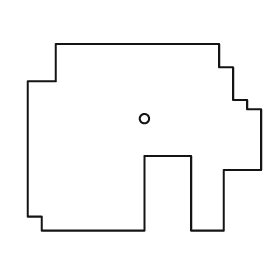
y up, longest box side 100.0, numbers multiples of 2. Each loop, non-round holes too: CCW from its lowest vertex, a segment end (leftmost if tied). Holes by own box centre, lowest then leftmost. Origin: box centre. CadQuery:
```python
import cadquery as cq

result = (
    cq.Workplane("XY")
    .moveTo(-44.0, -40.0)
    .lineTo(0.0, -40.0)
    .lineTo(0.0, -8.0)
    .lineTo(20.0, -8.0)
    .lineTo(20.0, -40.0)
    .lineTo(34.0, -40.0)
    .lineTo(34.0, -14.0)
    .lineTo(50.0, -14.0)
    .lineTo(50.0, 12.0)
    .lineTo(44.0, 12.0)
    .lineTo(44.0, 16.0)
    .lineTo(38.0, 16.0)
    .lineTo(38.0, 30.0)
    .lineTo(32.0, 30.0)
    .lineTo(32.0, 40.0)
    .lineTo(-38.0, 40.0)
    .lineTo(-38.0, 24.0)
    .lineTo(-50.0, 24.0)
    .lineTo(-50.0, -34.0)
    .lineTo(-44.0, -34.0)
    .close()
    .moveTo(0.0, 8.0)
    .circle(2.0)
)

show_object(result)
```